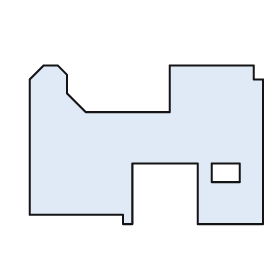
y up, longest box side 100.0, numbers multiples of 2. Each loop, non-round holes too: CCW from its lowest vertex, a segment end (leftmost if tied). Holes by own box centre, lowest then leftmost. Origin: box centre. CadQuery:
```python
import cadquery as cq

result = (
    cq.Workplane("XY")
    .moveTo(-10.0, -34.0)
    .lineTo(-6.0, -34.0)
    .lineTo(-6.0, -8.0)
    .lineTo(22.0, -8.0)
    .lineTo(22.0, -34.0)
    .lineTo(50.0, -34.0)
    .lineTo(50.0, 28.0)
    .lineTo(46.0, 28.0)
    .lineTo(46.0, 34.0)
    .lineTo(10.0, 34.0)
    .lineTo(10.0, 14.0)
    .lineTo(-26.0, 14.0)
    .lineTo(-34.0, 22.0)
    .lineTo(-34.0, 30.0)
    .lineTo(-38.0, 34.0)
    .lineTo(-44.0, 34.0)
    .lineTo(-50.0, 28.0)
    .lineTo(-50.0, -30.0)
    .lineTo(-10.0, -30.0)
    .close()
    .moveTo(28.0, -16.0)
    .lineTo(40.0, -16.0)
    .lineTo(40.0, -8.0)
    .lineTo(28.0, -8.0)
    .close()
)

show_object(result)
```